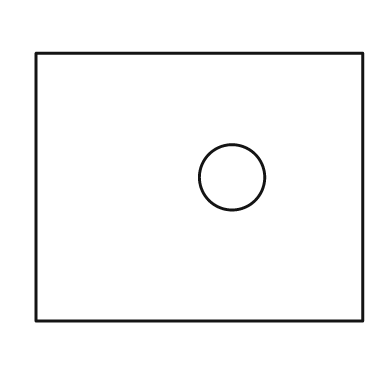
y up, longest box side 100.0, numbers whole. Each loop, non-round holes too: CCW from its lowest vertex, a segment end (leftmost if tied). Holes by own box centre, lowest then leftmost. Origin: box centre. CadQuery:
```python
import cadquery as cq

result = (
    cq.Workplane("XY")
    .moveTo(-50.0, -41.0)
    .lineTo(50.0, -41.0)
    .lineTo(50.0, 41.0)
    .lineTo(-50.0, 41.0)
    .close()
    .moveTo(10.0, 3.0)
    .circle(10.0)
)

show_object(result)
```